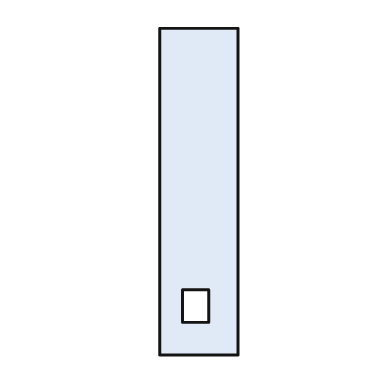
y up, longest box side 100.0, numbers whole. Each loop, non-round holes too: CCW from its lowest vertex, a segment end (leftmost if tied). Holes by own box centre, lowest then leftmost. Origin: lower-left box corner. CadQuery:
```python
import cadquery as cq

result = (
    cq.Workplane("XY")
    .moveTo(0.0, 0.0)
    .lineTo(24.0, 0.0)
    .lineTo(24.0, 100.0)
    .lineTo(0.0, 100.0)
    .close()
    .moveTo(7.0, 10.0)
    .lineTo(15.0, 10.0)
    .lineTo(15.0, 20.0)
    .lineTo(7.0, 20.0)
    .close()
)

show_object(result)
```